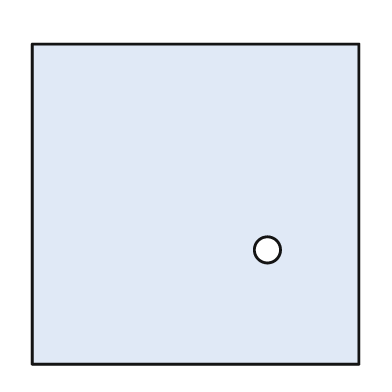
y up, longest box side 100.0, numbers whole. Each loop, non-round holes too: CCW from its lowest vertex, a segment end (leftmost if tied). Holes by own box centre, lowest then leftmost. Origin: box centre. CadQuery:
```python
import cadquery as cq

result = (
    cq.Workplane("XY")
    .moveTo(-50.0, -49.0)
    .lineTo(50.0, -49.0)
    .lineTo(50.0, 49.0)
    .lineTo(-50.0, 49.0)
    .close()
    .moveTo(22.0, -14.0)
    .circle(4.0)
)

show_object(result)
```